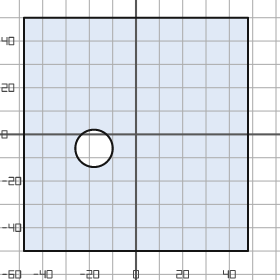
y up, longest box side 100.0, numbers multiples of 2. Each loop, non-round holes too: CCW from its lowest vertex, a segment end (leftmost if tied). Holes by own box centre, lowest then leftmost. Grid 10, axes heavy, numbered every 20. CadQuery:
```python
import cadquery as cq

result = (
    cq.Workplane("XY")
    .moveTo(-48.0, -50.0)
    .lineTo(48.0, -50.0)
    .lineTo(48.0, 50.0)
    .lineTo(-48.0, 50.0)
    .close()
    .moveTo(-18.0, -6.0)
    .circle(8.0)
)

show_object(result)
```